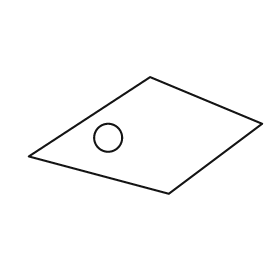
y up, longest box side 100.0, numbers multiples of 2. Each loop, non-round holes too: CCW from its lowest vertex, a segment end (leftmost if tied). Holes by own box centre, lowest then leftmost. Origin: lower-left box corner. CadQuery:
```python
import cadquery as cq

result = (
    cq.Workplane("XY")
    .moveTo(60.0, 0.0)
    .lineTo(100.0, 30.0)
    .lineTo(52.0, 50.0)
    .lineTo(0.0, 16.0)
    .close()
    .moveTo(34.0, 24.0)
    .circle(6.0)
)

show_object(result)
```